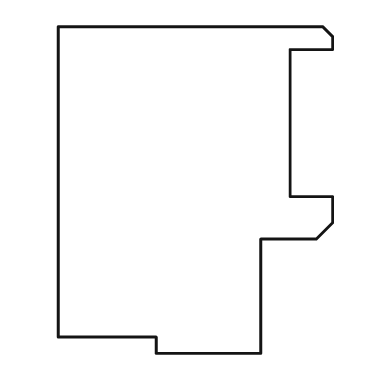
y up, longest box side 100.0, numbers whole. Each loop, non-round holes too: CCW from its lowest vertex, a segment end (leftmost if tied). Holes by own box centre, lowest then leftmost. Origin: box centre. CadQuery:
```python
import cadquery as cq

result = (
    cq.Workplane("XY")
    .moveTo(-12.0, -50.0)
    .lineTo(20.0, -50.0)
    .lineTo(20.0, -15.0)
    .lineTo(37.0, -15.0)
    .lineTo(42.0, -10.0)
    .lineTo(42.0, -2.0)
    .lineTo(29.0, -2.0)
    .lineTo(29.0, 43.0)
    .lineTo(42.0, 43.0)
    .lineTo(42.0, 47.0)
    .lineTo(39.0, 50.0)
    .lineTo(-42.0, 50.0)
    .lineTo(-42.0, -45.0)
    .lineTo(-12.0, -45.0)
    .close()
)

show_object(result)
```